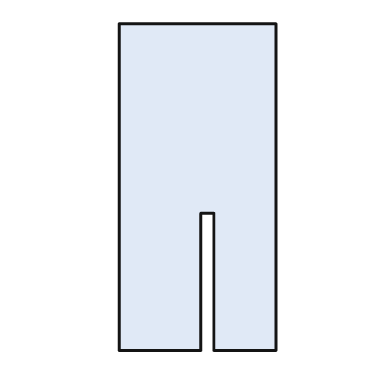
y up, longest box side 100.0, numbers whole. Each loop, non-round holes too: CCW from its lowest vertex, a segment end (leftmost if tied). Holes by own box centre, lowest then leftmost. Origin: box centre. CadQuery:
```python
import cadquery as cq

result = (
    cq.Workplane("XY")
    .moveTo(-24.0, -50.0)
    .lineTo(1.0, -50.0)
    .lineTo(1.0, -8.0)
    .lineTo(5.0, -8.0)
    .lineTo(5.0, -50.0)
    .lineTo(24.0, -50.0)
    .lineTo(24.0, 50.0)
    .lineTo(-24.0, 50.0)
    .close()
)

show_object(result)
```